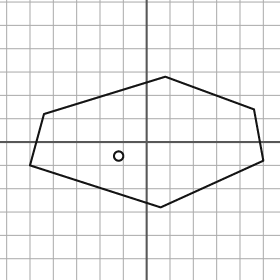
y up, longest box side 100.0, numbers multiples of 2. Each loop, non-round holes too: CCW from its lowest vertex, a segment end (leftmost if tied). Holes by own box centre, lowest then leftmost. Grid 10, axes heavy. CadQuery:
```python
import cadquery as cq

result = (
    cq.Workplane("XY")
    .moveTo(6.0, -28.0)
    .lineTo(50.0, -8.0)
    .lineTo(46.0, 14.0)
    .lineTo(8.0, 28.0)
    .lineTo(-44.0, 12.0)
    .lineTo(-50.0, -10.0)
    .close()
    .moveTo(-12.0, -6.0)
    .circle(2.0)
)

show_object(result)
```